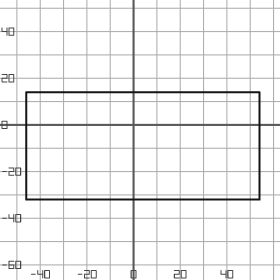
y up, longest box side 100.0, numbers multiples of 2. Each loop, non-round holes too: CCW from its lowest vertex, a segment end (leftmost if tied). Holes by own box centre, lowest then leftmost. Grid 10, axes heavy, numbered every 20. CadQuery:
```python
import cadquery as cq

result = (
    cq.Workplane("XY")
    .moveTo(-46.0, -32.0)
    .lineTo(54.0, -32.0)
    .lineTo(54.0, 14.0)
    .lineTo(-46.0, 14.0)
    .close()
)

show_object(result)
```